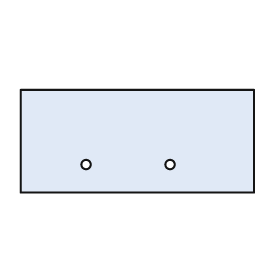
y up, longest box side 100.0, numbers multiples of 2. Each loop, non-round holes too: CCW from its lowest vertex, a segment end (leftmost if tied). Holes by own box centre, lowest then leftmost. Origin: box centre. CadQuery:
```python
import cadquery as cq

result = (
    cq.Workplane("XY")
    .moveTo(-50.0, -22.0)
    .lineTo(50.0, -22.0)
    .lineTo(50.0, 22.0)
    .lineTo(-50.0, 22.0)
    .close()
    .moveTo(-22.0, -10.0)
    .circle(2.0)
    .moveTo(14.0, -10.0)
    .circle(2.0)
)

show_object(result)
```